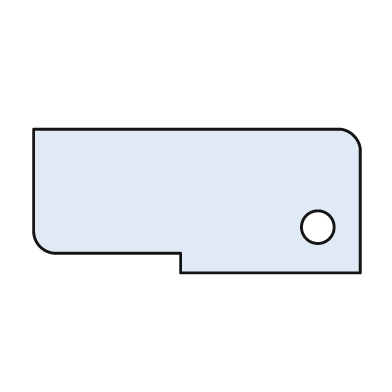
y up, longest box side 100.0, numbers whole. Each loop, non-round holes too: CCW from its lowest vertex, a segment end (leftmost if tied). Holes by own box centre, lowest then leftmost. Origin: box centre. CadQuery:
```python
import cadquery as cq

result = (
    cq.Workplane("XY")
    .moveTo(-5.0, -22.0)
    .lineTo(50.0, -22.0)
    .lineTo(50.0, 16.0)
    .threePointArc((48.0, 20.0), (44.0, 22.0))
    .lineTo(-50.0, 22.0)
    .lineTo(-50.0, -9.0)
    .threePointArc((-48.0, -14.0), (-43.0, -16.0))
    .lineTo(-5.0, -16.0)
    .close()
    .moveTo(37.0, -8.0)
    .circle(5.0)
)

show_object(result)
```